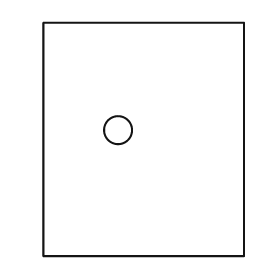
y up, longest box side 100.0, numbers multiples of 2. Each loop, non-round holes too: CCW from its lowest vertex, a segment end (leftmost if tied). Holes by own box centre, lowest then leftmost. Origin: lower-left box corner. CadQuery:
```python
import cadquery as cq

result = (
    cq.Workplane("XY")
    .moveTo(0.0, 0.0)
    .lineTo(86.0, 0.0)
    .lineTo(86.0, 100.0)
    .lineTo(0.0, 100.0)
    .close()
    .moveTo(32.0, 54.0)
    .circle(6.0)
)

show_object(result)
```